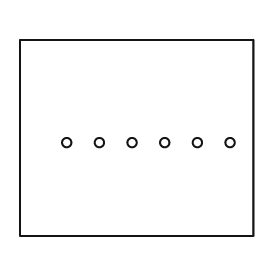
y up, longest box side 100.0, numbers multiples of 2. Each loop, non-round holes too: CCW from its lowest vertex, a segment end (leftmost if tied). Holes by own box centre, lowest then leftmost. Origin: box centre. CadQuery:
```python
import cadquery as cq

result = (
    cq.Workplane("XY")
    .moveTo(-50.0, -42.0)
    .lineTo(50.0, -42.0)
    .lineTo(50.0, 42.0)
    .lineTo(-50.0, 42.0)
    .close()
    .moveTo(-30.0, -2.0)
    .circle(2.0)
    .moveTo(-16.0, -2.0)
    .circle(2.0)
    .moveTo(-2.0, -2.0)
    .circle(2.0)
    .moveTo(12.0, -2.0)
    .circle(2.0)
    .moveTo(26.0, -2.0)
    .circle(2.0)
    .moveTo(40.0, -2.0)
    .circle(2.0)
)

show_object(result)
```